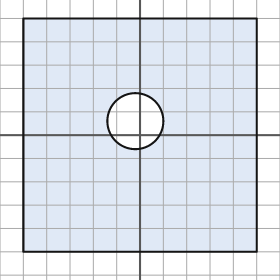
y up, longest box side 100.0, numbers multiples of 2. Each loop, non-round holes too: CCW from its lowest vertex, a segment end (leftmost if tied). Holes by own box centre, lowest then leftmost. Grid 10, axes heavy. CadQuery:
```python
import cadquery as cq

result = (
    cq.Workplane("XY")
    .moveTo(-50.0, -50.0)
    .lineTo(50.0, -50.0)
    .lineTo(50.0, 50.0)
    .lineTo(-50.0, 50.0)
    .close()
    .moveTo(-2.0, 6.0)
    .circle(12.0)
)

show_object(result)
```